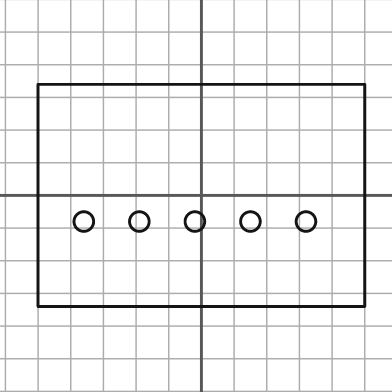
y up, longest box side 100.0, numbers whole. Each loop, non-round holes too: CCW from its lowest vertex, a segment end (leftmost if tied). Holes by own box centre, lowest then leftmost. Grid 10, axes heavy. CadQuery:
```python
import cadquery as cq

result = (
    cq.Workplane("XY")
    .moveTo(-50.0, -34.0)
    .lineTo(50.0, -34.0)
    .lineTo(50.0, 34.0)
    .lineTo(-50.0, 34.0)
    .close()
    .moveTo(-36.0, -8.0)
    .circle(3.0)
    .moveTo(-19.0, -8.0)
    .circle(3.0)
    .moveTo(-2.0, -8.0)
    .circle(3.0)
    .moveTo(15.0, -8.0)
    .circle(3.0)
    .moveTo(32.0, -8.0)
    .circle(3.0)
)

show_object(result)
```